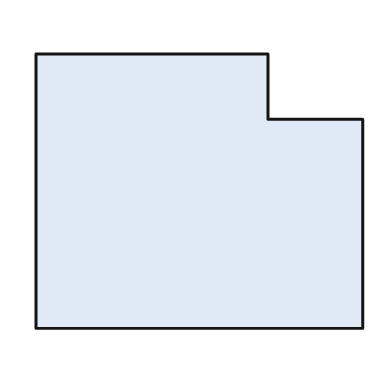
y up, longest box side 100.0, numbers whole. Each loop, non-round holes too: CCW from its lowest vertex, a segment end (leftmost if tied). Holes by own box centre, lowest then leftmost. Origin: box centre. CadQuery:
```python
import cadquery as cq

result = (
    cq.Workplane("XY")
    .moveTo(-50.0, -42.0)
    .lineTo(50.0, -42.0)
    .lineTo(50.0, 22.0)
    .lineTo(21.0, 22.0)
    .lineTo(21.0, 42.0)
    .lineTo(-50.0, 42.0)
    .close()
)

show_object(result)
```